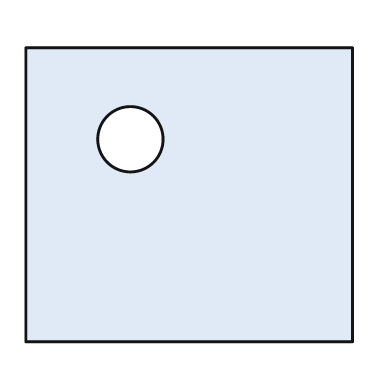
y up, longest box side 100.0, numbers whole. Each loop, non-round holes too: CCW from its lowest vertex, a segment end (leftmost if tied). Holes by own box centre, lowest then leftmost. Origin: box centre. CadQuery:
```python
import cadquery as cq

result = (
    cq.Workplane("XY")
    .moveTo(-50.0, -45.0)
    .lineTo(50.0, -45.0)
    .lineTo(50.0, 45.0)
    .lineTo(-50.0, 45.0)
    .close()
    .moveTo(-18.0, 17.0)
    .circle(10.0)
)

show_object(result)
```